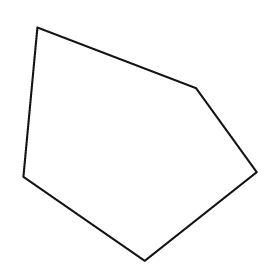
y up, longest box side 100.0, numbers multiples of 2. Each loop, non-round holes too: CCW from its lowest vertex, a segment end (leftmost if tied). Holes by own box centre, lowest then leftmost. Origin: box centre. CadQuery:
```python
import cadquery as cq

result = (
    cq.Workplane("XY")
    .moveTo(2.0, -50.0)
    .lineTo(50.0, -12.0)
    .lineTo(24.0, 24.0)
    .lineTo(-44.0, 50.0)
    .lineTo(-50.0, -14.0)
    .close()
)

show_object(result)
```